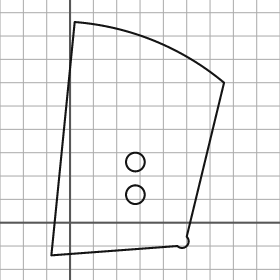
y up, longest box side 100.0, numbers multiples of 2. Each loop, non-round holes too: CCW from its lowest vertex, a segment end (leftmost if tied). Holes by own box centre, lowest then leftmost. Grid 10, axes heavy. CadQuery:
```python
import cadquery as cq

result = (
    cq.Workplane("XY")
    .moveTo(-8.0, -14.0)
    .lineTo(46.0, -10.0)
    .threePointArc((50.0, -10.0), (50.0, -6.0))
    .lineTo(66.0, 60.0)
    .threePointArc((36.0, 78.0), (2.0, 86.0))
    .close()
    .moveTo(28.0, 12.0)
    .circle(4.0)
    .moveTo(28.0, 26.0)
    .circle(4.0)
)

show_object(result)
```